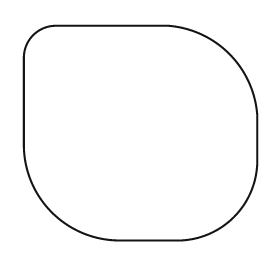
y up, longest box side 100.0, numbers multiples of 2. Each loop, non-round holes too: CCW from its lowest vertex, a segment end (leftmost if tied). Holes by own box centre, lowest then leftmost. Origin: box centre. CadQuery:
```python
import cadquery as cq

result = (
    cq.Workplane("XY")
    .moveTo(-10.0, -46.0)
    .lineTo(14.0, -46.0)
    .threePointArc((40.0, -36.0), (50.0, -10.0))
    .lineTo(50.0, 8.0)
    .threePointArc((38.0, 34.0), (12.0, 46.0))
    .lineTo(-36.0, 46.0)
    .threePointArc((-46.0, 42.0), (-50.0, 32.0))
    .lineTo(-50.0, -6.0)
    .threePointArc((-38.0, -34.0), (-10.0, -46.0))
    .close()
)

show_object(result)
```